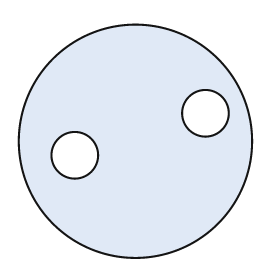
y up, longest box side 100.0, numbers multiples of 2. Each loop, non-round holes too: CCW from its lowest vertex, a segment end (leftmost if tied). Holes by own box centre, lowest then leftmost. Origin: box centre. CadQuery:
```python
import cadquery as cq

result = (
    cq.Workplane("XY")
    .moveTo(0.0, 0.0)
    .circle(50.0)
    .moveTo(-26.0, -6.0)
    .circle(10.0)
    .moveTo(30.0, 12.0)
    .circle(10.0)
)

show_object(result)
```